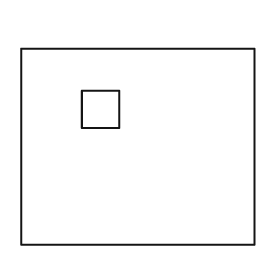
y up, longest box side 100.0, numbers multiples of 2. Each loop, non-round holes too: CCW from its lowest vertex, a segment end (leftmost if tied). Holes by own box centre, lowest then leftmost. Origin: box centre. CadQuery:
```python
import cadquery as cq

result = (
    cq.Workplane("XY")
    .moveTo(-50.0, -42.0)
    .lineTo(50.0, -42.0)
    .lineTo(50.0, 42.0)
    .lineTo(-50.0, 42.0)
    .close()
    .moveTo(-24.0, 8.0)
    .lineTo(-8.0, 8.0)
    .lineTo(-8.0, 24.0)
    .lineTo(-24.0, 24.0)
    .close()
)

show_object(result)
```